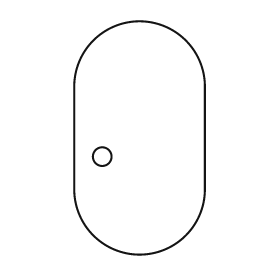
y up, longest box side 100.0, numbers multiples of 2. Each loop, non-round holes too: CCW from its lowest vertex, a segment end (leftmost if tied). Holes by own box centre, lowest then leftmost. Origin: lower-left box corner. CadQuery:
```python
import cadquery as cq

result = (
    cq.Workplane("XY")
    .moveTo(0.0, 28.0)
    .threePointArc((28.0, 0.0), (56.0, 28.0))
    .lineTo(56.0, 72.0)
    .threePointArc((28.0, 100.0), (0.0, 72.0))
    .close()
    .moveTo(12.0, 42.0)
    .circle(4.0)
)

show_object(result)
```